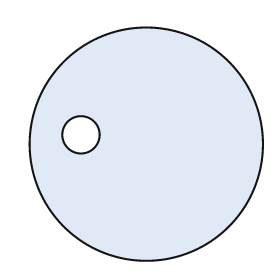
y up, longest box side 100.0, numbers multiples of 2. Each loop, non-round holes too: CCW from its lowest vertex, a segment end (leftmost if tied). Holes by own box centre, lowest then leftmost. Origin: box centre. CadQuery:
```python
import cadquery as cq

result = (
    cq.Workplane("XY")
    .moveTo(0.0, 0.0)
    .circle(50.0)
    .moveTo(-28.0, 4.0)
    .circle(8.0)
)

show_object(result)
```